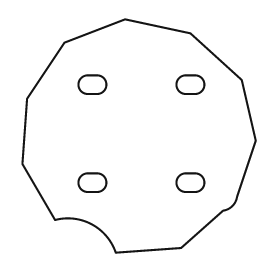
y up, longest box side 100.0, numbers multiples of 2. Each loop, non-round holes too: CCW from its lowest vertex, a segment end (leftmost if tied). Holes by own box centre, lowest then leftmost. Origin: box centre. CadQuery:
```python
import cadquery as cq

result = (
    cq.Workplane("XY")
    .moveTo(-10.0, -50.0)
    .lineTo(18.0, -48.0)
    .lineTo(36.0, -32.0)
    .threePointArc((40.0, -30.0), (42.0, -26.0))
    .lineTo(50.0, -2.0)
    .lineTo(44.0, 24.0)
    .lineTo(22.0, 44.0)
    .lineTo(-6.0, 50.0)
    .lineTo(-32.0, 40.0)
    .lineTo(-48.0, 16.0)
    .lineTo(-50.0, -12.0)
    .lineTo(-36.0, -36.0)
    .threePointArc((-20.0, -38.0), (-10.0, -50.0))
    .close()
    .moveTo(-22.0, -24.0)
    .lineTo(-18.0, -24.0)
    .threePointArc((-14.0, -20.0), (-18.0, -16.0))
    .lineTo(-22.0, -16.0)
    .threePointArc((-26.0, -20.0), (-22.0, -24.0))
    .close()
    .moveTo(20.0, -24.0)
    .lineTo(24.0, -24.0)
    .threePointArc((28.0, -20.0), (24.0, -16.0))
    .lineTo(20.0, -16.0)
    .threePointArc((16.0, -20.0), (20.0, -24.0))
    .close()
    .moveTo(-22.0, 18.0)
    .lineTo(-18.0, 18.0)
    .threePointArc((-14.0, 22.0), (-18.0, 26.0))
    .lineTo(-22.0, 26.0)
    .threePointArc((-26.0, 22.0), (-22.0, 18.0))
    .close()
    .moveTo(20.0, 18.0)
    .lineTo(24.0, 18.0)
    .threePointArc((28.0, 22.0), (24.0, 26.0))
    .lineTo(20.0, 26.0)
    .threePointArc((16.0, 22.0), (20.0, 18.0))
    .close()
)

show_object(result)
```